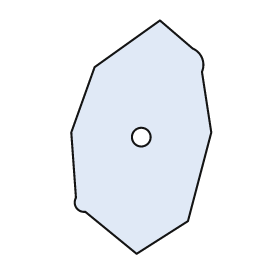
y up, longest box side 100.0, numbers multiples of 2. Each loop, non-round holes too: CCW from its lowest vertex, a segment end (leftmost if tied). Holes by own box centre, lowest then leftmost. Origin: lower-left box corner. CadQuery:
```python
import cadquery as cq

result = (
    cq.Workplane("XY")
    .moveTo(28.0, 0.0)
    .lineTo(50.0, 14.0)
    .lineTo(60.0, 52.0)
    .lineTo(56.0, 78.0)
    .threePointArc((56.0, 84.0), (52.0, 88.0))
    .lineTo(38.0, 100.0)
    .lineTo(10.0, 80.0)
    .lineTo(0.0, 52.0)
    .lineTo(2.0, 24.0)
    .threePointArc((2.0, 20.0), (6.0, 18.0))
    .close()
    .moveTo(30.0, 50.0)
    .circle(4.0)
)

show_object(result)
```